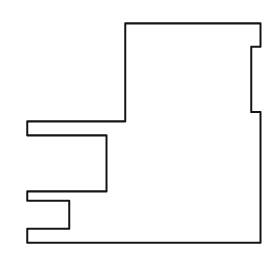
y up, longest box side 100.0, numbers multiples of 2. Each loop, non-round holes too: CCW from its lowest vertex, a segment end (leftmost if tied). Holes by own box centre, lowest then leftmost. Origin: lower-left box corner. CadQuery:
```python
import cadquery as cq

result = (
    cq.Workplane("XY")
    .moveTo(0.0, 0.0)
    .lineTo(100.0, 0.0)
    .lineTo(100.0, 56.0)
    .lineTo(96.0, 56.0)
    .lineTo(96.0, 84.0)
    .lineTo(100.0, 84.0)
    .lineTo(100.0, 94.0)
    .lineTo(42.0, 94.0)
    .lineTo(42.0, 52.0)
    .lineTo(0.0, 52.0)
    .lineTo(0.0, 46.0)
    .lineTo(34.0, 46.0)
    .lineTo(34.0, 22.0)
    .lineTo(0.0, 22.0)
    .lineTo(0.0, 18.0)
    .lineTo(18.0, 18.0)
    .lineTo(18.0, 6.0)
    .lineTo(0.0, 6.0)
    .close()
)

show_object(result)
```